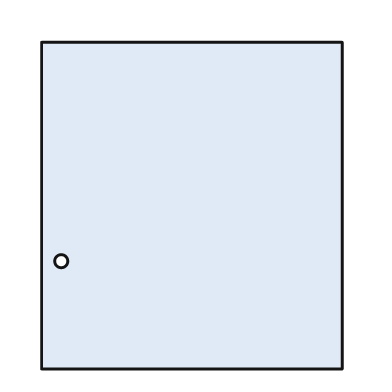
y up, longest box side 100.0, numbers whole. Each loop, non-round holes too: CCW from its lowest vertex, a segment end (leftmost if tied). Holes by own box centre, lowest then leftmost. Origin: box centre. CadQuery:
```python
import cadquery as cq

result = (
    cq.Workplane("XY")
    .moveTo(-46.0, -50.0)
    .lineTo(46.0, -50.0)
    .lineTo(46.0, 50.0)
    .lineTo(-46.0, 50.0)
    .close()
    .moveTo(-40.0, -17.0)
    .circle(2.0)
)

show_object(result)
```